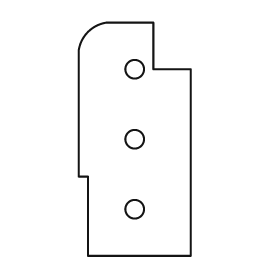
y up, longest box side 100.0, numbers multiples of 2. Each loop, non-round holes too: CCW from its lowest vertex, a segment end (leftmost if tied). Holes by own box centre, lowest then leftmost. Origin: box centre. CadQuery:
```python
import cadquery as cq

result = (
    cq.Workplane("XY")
    .moveTo(-20.0, -50.0)
    .lineTo(24.0, -50.0)
    .lineTo(24.0, 30.0)
    .lineTo(8.0, 30.0)
    .lineTo(8.0, 50.0)
    .lineTo(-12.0, 50.0)
    .threePointArc((-20.0, 46.0), (-24.0, 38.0))
    .lineTo(-24.0, -16.0)
    .lineTo(-20.0, -16.0)
    .close()
    .moveTo(0.0, -30.0)
    .circle(4.0)
    .moveTo(0.0, 0.0)
    .circle(4.0)
    .moveTo(0.0, 30.0)
    .circle(4.0)
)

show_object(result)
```